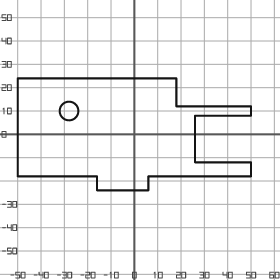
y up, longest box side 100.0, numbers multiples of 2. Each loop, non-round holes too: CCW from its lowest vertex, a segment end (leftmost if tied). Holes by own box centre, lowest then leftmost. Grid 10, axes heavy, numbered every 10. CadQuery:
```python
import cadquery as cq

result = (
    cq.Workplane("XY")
    .moveTo(-16.0, -24.0)
    .lineTo(6.0, -24.0)
    .lineTo(6.0, -18.0)
    .lineTo(50.0, -18.0)
    .lineTo(50.0, -12.0)
    .lineTo(26.0, -12.0)
    .lineTo(26.0, 8.0)
    .lineTo(50.0, 8.0)
    .lineTo(50.0, 12.0)
    .lineTo(18.0, 12.0)
    .lineTo(18.0, 24.0)
    .lineTo(-50.0, 24.0)
    .lineTo(-50.0, -18.0)
    .lineTo(-16.0, -18.0)
    .close()
    .moveTo(-28.0, 10.0)
    .circle(4.0)
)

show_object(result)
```